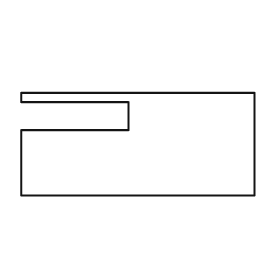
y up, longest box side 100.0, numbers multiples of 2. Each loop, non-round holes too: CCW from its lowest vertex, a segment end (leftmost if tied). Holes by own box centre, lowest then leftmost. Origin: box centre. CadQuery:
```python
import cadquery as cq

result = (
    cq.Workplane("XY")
    .moveTo(-50.0, -22.0)
    .lineTo(50.0, -22.0)
    .lineTo(50.0, 22.0)
    .lineTo(-50.0, 22.0)
    .lineTo(-50.0, 18.0)
    .lineTo(-4.0, 18.0)
    .lineTo(-4.0, 6.0)
    .lineTo(-50.0, 6.0)
    .close()
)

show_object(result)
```